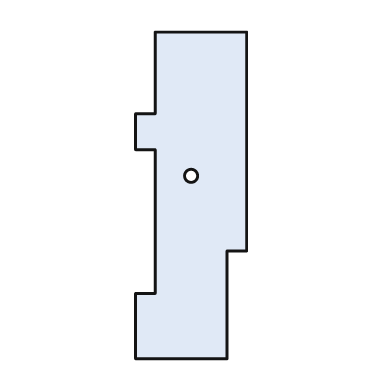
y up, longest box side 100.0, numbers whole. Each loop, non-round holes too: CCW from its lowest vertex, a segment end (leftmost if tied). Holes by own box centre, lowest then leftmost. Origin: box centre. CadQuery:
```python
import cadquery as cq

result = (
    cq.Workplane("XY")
    .moveTo(-17.0, -50.0)
    .lineTo(11.0, -50.0)
    .lineTo(11.0, -17.0)
    .lineTo(17.0, -17.0)
    .lineTo(17.0, 50.0)
    .lineTo(-11.0, 50.0)
    .lineTo(-11.0, 25.0)
    .lineTo(-17.0, 25.0)
    .lineTo(-17.0, 14.0)
    .lineTo(-11.0, 14.0)
    .lineTo(-11.0, -30.0)
    .lineTo(-17.0, -30.0)
    .close()
    .moveTo(0.0, 6.0)
    .circle(2.0)
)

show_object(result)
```